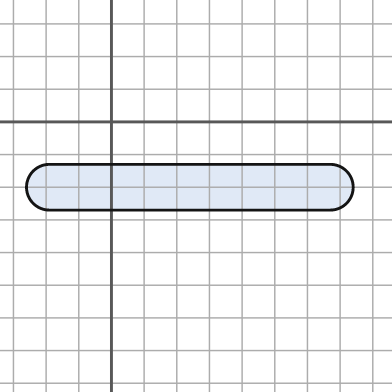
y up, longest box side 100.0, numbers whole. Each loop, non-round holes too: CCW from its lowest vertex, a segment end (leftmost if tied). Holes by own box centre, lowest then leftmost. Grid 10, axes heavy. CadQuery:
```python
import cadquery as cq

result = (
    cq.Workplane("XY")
    .moveTo(-19.0, -27.0)
    .lineTo(67.0, -27.0)
    .threePointArc((74.0, -20.0), (67.0, -13.0))
    .lineTo(-19.0, -13.0)
    .threePointArc((-26.0, -20.0), (-19.0, -27.0))
    .close()
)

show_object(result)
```